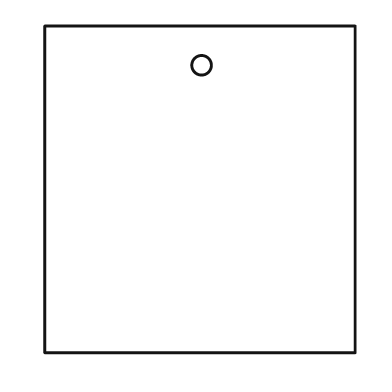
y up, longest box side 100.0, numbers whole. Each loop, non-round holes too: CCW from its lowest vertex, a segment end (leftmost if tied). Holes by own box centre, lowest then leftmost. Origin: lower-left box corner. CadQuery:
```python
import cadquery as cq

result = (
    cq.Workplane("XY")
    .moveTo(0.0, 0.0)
    .lineTo(95.0, 0.0)
    .lineTo(95.0, 100.0)
    .lineTo(0.0, 100.0)
    .close()
    .moveTo(48.0, 88.0)
    .circle(3.0)
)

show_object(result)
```